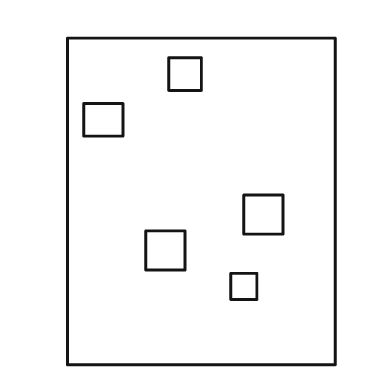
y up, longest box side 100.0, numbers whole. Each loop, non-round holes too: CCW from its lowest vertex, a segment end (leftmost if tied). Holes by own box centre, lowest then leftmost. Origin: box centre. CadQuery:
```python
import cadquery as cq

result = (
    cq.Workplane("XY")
    .moveTo(-41.0, -50.0)
    .lineTo(41.0, -50.0)
    .lineTo(41.0, 50.0)
    .lineTo(-41.0, 50.0)
    .close()
    .moveTo(9.0, -30.0)
    .lineTo(17.0, -30.0)
    .lineTo(17.0, -22.0)
    .lineTo(9.0, -22.0)
    .close()
    .moveTo(-17.0, -21.0)
    .lineTo(-5.0, -21.0)
    .lineTo(-5.0, -9.0)
    .lineTo(-17.0, -9.0)
    .close()
    .moveTo(13.0, -10.0)
    .lineTo(25.0, -10.0)
    .lineTo(25.0, 2.0)
    .lineTo(13.0, 2.0)
    .close()
    .moveTo(-36.0, 20.0)
    .lineTo(-24.0, 20.0)
    .lineTo(-24.0, 30.0)
    .lineTo(-36.0, 30.0)
    .close()
    .moveTo(-10.0, 34.0)
    .lineTo(0.0, 34.0)
    .lineTo(0.0, 44.0)
    .lineTo(-10.0, 44.0)
    .close()
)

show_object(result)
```